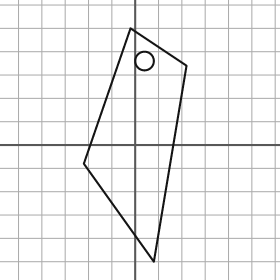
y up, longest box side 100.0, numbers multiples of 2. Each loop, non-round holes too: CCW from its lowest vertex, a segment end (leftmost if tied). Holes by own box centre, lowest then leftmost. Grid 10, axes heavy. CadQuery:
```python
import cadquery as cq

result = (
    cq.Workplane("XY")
    .moveTo(8.0, -50.0)
    .lineTo(22.0, 34.0)
    .lineTo(-2.0, 50.0)
    .lineTo(-22.0, -8.0)
    .close()
    .moveTo(4.0, 36.0)
    .circle(4.0)
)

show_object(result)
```